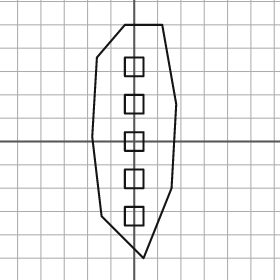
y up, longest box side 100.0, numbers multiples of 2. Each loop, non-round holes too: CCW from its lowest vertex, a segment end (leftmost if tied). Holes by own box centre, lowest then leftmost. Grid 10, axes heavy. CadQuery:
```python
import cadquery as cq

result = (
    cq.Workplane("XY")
    .moveTo(4.0, -50.0)
    .lineTo(16.0, -20.0)
    .lineTo(18.0, 16.0)
    .lineTo(12.0, 50.0)
    .lineTo(-4.0, 50.0)
    .lineTo(-16.0, 36.0)
    .lineTo(-18.0, 2.0)
    .lineTo(-14.0, -32.0)
    .close()
    .moveTo(-4.0, -36.0)
    .lineTo(4.0, -36.0)
    .lineTo(4.0, -28.0)
    .lineTo(-4.0, -28.0)
    .close()
    .moveTo(-4.0, -20.0)
    .lineTo(4.0, -20.0)
    .lineTo(4.0, -12.0)
    .lineTo(-4.0, -12.0)
    .close()
    .moveTo(-4.0, -4.0)
    .lineTo(4.0, -4.0)
    .lineTo(4.0, 4.0)
    .lineTo(-4.0, 4.0)
    .close()
    .moveTo(-4.0, 12.0)
    .lineTo(4.0, 12.0)
    .lineTo(4.0, 20.0)
    .lineTo(-4.0, 20.0)
    .close()
    .moveTo(-4.0, 28.0)
    .lineTo(4.0, 28.0)
    .lineTo(4.0, 36.0)
    .lineTo(-4.0, 36.0)
    .close()
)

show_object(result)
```